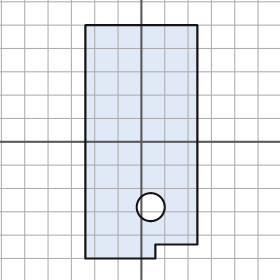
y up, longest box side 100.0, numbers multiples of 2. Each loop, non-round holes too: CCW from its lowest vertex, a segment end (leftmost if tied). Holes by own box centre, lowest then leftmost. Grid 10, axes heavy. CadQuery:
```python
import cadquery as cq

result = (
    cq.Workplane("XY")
    .moveTo(-24.0, -50.0)
    .lineTo(6.0, -50.0)
    .lineTo(6.0, -44.0)
    .lineTo(24.0, -44.0)
    .lineTo(24.0, 50.0)
    .lineTo(-24.0, 50.0)
    .close()
    .moveTo(4.0, -28.0)
    .circle(6.0)
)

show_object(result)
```